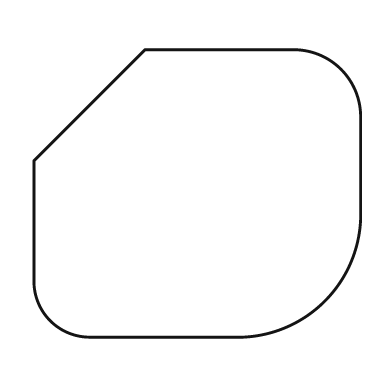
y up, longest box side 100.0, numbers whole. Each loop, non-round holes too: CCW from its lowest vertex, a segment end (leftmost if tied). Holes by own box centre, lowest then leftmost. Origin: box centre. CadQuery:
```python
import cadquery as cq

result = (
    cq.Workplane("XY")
    .moveTo(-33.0, -44.0)
    .lineTo(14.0, -44.0)
    .threePointArc((39.0, -33.0), (50.0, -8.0))
    .lineTo(50.0, 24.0)
    .threePointArc((44.0, 38.0), (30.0, 44.0))
    .lineTo(-16.0, 44.0)
    .lineTo(-50.0, 10.0)
    .lineTo(-50.0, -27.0)
    .threePointArc((-45.0, -39.0), (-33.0, -44.0))
    .close()
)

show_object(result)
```